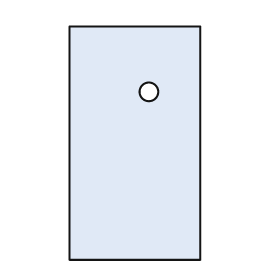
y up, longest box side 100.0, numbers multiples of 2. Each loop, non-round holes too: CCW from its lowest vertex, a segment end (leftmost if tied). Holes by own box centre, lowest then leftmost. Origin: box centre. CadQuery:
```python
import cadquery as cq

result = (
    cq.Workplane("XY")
    .moveTo(-28.0, -50.0)
    .lineTo(28.0, -50.0)
    .lineTo(28.0, 50.0)
    .lineTo(-28.0, 50.0)
    .close()
    .moveTo(6.0, 22.0)
    .circle(4.0)
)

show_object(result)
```